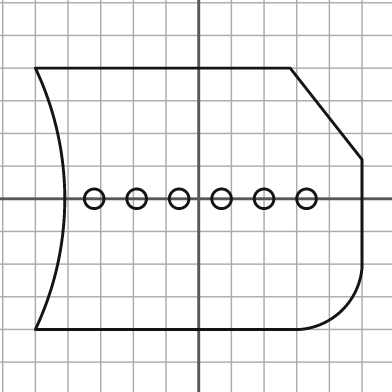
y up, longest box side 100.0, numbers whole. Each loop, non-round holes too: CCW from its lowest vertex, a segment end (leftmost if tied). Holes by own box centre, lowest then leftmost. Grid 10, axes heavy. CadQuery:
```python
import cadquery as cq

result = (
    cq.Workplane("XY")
    .moveTo(-50.0, -40.0)
    .lineTo(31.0, -40.0)
    .threePointArc((44.0, -34.0), (50.0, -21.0))
    .lineTo(50.0, 12.0)
    .lineTo(28.0, 40.0)
    .lineTo(-50.0, 40.0)
    .threePointArc((-41.0, 0.0), (-50.0, -40.0))
    .close()
    .moveTo(-32.0, 0.0)
    .circle(3.0)
    .moveTo(-19.0, 0.0)
    .circle(3.0)
    .moveTo(-6.0, 0.0)
    .circle(3.0)
    .moveTo(7.0, 0.0)
    .circle(3.0)
    .moveTo(20.0, 0.0)
    .circle(3.0)
    .moveTo(33.0, 0.0)
    .circle(3.0)
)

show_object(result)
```